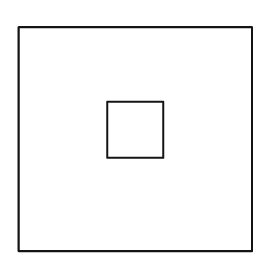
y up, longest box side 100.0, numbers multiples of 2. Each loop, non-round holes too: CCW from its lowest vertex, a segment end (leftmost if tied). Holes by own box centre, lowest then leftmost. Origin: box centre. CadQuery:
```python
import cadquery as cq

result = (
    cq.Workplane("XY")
    .moveTo(-50.0, -48.0)
    .lineTo(50.0, -48.0)
    .lineTo(50.0, 48.0)
    .lineTo(-50.0, 48.0)
    .close()
    .moveTo(-12.0, -8.0)
    .lineTo(12.0, -8.0)
    .lineTo(12.0, 16.0)
    .lineTo(-12.0, 16.0)
    .close()
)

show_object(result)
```